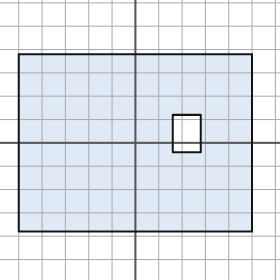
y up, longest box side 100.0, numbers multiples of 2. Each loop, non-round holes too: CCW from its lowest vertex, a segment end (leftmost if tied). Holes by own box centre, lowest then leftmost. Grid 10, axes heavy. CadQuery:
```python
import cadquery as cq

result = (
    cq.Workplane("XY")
    .moveTo(-50.0, -38.0)
    .lineTo(50.0, -38.0)
    .lineTo(50.0, 38.0)
    .lineTo(-50.0, 38.0)
    .close()
    .moveTo(16.0, -4.0)
    .lineTo(28.0, -4.0)
    .lineTo(28.0, 12.0)
    .lineTo(16.0, 12.0)
    .close()
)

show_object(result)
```